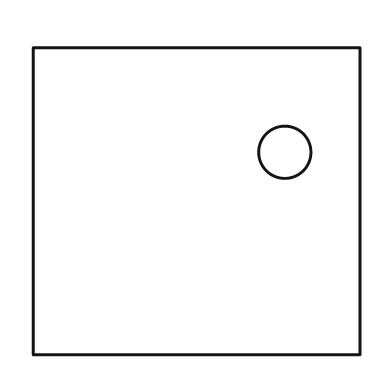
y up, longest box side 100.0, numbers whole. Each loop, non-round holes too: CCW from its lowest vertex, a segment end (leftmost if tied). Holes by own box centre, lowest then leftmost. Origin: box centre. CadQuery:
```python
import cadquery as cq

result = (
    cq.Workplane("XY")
    .moveTo(-50.0, -47.0)
    .lineTo(50.0, -47.0)
    .lineTo(50.0, 47.0)
    .lineTo(-50.0, 47.0)
    .close()
    .moveTo(27.0, 15.0)
    .circle(8.0)
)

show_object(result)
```